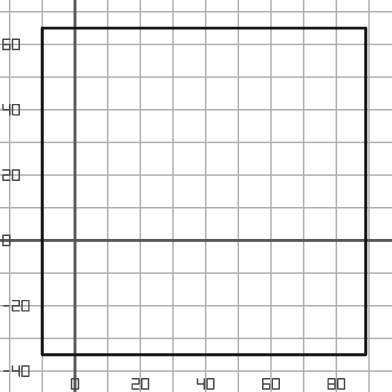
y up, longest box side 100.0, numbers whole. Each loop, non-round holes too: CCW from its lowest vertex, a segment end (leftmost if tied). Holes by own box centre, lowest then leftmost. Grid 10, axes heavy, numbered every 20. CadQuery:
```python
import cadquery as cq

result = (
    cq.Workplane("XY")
    .moveTo(-10.0, -35.0)
    .lineTo(89.0, -35.0)
    .lineTo(89.0, 65.0)
    .lineTo(-10.0, 65.0)
    .close()
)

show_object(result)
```